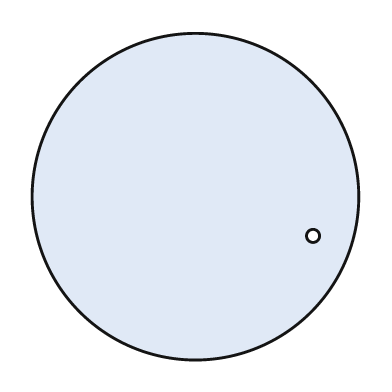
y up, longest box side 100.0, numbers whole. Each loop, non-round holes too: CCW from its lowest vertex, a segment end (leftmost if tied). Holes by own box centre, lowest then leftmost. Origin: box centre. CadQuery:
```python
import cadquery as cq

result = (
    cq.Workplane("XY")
    .moveTo(0.0, 0.0)
    .circle(50.0)
    .moveTo(36.0, -12.0)
    .circle(2.0)
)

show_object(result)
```